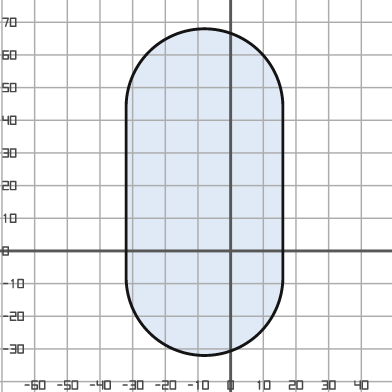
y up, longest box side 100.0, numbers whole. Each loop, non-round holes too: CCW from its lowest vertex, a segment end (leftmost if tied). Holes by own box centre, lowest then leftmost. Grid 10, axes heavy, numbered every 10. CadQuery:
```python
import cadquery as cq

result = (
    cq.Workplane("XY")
    .moveTo(-32.0, -8.0)
    .threePointArc((-8.0, -32.0), (16.0, -8.0))
    .lineTo(16.0, 44.0)
    .threePointArc((-8.0, 68.0), (-32.0, 44.0))
    .close()
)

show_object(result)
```